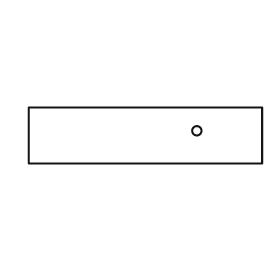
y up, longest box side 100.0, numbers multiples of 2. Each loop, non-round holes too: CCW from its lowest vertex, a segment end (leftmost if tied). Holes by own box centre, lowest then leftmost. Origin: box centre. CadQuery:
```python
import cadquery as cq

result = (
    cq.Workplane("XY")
    .moveTo(-50.0, -12.0)
    .lineTo(50.0, -12.0)
    .lineTo(50.0, 12.0)
    .lineTo(-50.0, 12.0)
    .close()
    .moveTo(22.0, 2.0)
    .circle(2.0)
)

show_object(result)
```